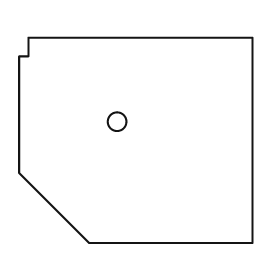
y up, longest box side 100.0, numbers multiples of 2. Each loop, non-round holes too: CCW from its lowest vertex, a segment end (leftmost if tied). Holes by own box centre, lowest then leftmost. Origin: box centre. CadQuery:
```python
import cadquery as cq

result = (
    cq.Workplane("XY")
    .moveTo(-20.0, -44.0)
    .lineTo(50.0, -44.0)
    .lineTo(50.0, 44.0)
    .lineTo(-46.0, 44.0)
    .lineTo(-46.0, 36.0)
    .lineTo(-50.0, 36.0)
    .lineTo(-50.0, -14.0)
    .close()
    .moveTo(-8.0, 8.0)
    .circle(4.0)
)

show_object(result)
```